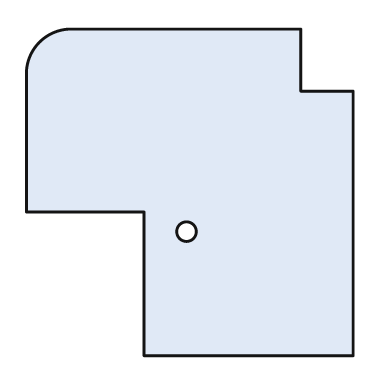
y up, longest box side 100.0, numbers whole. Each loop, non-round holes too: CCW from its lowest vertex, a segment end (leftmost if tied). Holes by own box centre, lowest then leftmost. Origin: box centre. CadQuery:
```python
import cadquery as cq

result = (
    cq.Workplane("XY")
    .moveTo(-14.0, -50.0)
    .lineTo(50.0, -50.0)
    .lineTo(50.0, 31.0)
    .lineTo(34.0, 31.0)
    .lineTo(34.0, 50.0)
    .lineTo(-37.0, 50.0)
    .threePointArc((-46.0, 46.0), (-50.0, 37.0))
    .lineTo(-50.0, -6.0)
    .lineTo(-14.0, -6.0)
    .close()
    .moveTo(-1.0, -12.0)
    .circle(3.0)
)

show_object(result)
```